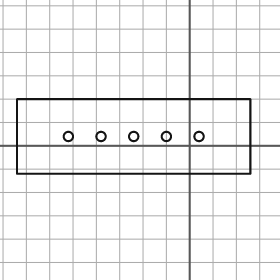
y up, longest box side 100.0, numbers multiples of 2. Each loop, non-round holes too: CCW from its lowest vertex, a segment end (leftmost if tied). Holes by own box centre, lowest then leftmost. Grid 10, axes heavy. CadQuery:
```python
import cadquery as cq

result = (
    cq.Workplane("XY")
    .moveTo(-74.0, -12.0)
    .lineTo(26.0, -12.0)
    .lineTo(26.0, 20.0)
    .lineTo(-74.0, 20.0)
    .close()
    .moveTo(-52.0, 4.0)
    .circle(2.0)
    .moveTo(-38.0, 4.0)
    .circle(2.0)
    .moveTo(-24.0, 4.0)
    .circle(2.0)
    .moveTo(-10.0, 4.0)
    .circle(2.0)
    .moveTo(4.0, 4.0)
    .circle(2.0)
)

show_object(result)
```